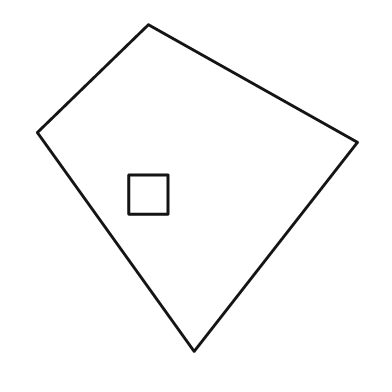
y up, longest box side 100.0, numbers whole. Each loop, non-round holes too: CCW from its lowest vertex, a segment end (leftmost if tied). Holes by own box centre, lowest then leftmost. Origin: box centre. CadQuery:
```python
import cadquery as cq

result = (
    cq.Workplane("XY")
    .moveTo(-1.0, -50.0)
    .lineTo(49.0, 14.0)
    .lineTo(-15.0, 50.0)
    .lineTo(-49.0, 17.0)
    .close()
    .moveTo(-21.0, -8.0)
    .lineTo(-9.0, -8.0)
    .lineTo(-9.0, 4.0)
    .lineTo(-21.0, 4.0)
    .close()
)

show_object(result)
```